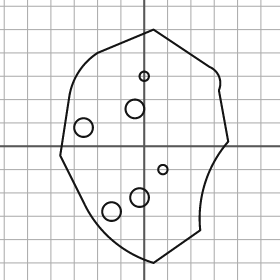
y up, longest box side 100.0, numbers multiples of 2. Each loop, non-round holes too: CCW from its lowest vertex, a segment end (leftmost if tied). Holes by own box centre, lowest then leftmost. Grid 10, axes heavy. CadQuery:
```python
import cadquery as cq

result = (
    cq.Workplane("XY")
    .moveTo(4.0, -50.0)
    .lineTo(24.0, -36.0)
    .threePointArc((26.0, -16.0), (36.0, 2.0))
    .lineTo(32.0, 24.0)
    .threePointArc((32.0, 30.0), (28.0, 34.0))
    .lineTo(4.0, 50.0)
    .lineTo(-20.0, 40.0)
    .threePointArc((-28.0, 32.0), (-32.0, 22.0))
    .lineTo(-36.0, -4.0)
    .lineTo(-26.0, -24.0)
    .threePointArc((-14.0, -40.0), (4.0, -50.0))
    .close()
    .moveTo(-14.0, -28.0)
    .circle(4.0)
    .moveTo(-2.0, -22.0)
    .circle(4.0)
    .moveTo(8.0, -10.0)
    .circle(2.0)
    .moveTo(-26.0, 8.0)
    .circle(4.0)
    .moveTo(-4.0, 16.0)
    .circle(4.0)
    .moveTo(0.0, 30.0)
    .circle(2.0)
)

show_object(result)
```